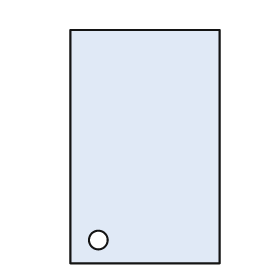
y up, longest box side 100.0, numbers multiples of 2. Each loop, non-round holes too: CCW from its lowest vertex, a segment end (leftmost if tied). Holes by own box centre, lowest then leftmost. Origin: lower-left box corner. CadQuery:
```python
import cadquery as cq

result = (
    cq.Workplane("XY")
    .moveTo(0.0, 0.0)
    .lineTo(64.0, 0.0)
    .lineTo(64.0, 100.0)
    .lineTo(0.0, 100.0)
    .close()
    .moveTo(12.0, 10.0)
    .circle(4.0)
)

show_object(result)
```